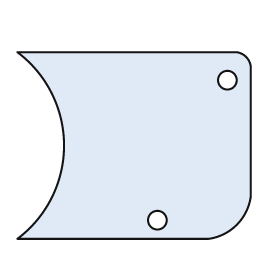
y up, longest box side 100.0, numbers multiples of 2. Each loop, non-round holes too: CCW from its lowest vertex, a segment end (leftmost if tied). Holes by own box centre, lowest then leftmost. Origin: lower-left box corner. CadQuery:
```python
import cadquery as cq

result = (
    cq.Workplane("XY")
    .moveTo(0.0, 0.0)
    .lineTo(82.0, 0.0)
    .threePointArc((94.0, 6.0), (100.0, 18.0))
    .lineTo(100.0, 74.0)
    .threePointArc((98.0, 78.0), (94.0, 80.0))
    .lineTo(0.0, 80.0)
    .threePointArc((20.0, 40.0), (0.0, 0.0))
    .close()
    .moveTo(60.0, 8.0)
    .circle(4.0)
    .moveTo(90.0, 68.0)
    .circle(4.0)
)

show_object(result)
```